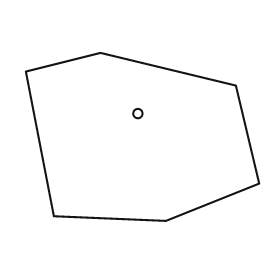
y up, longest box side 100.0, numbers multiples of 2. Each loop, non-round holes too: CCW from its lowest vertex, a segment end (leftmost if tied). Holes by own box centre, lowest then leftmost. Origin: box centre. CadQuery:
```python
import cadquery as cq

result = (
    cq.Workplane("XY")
    .moveTo(10.0, -36.0)
    .lineTo(50.0, -20.0)
    .lineTo(40.0, 22.0)
    .lineTo(-18.0, 36.0)
    .lineTo(-50.0, 28.0)
    .lineTo(-38.0, -34.0)
    .close()
    .moveTo(-2.0, 10.0)
    .circle(2.0)
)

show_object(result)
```